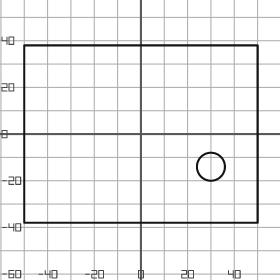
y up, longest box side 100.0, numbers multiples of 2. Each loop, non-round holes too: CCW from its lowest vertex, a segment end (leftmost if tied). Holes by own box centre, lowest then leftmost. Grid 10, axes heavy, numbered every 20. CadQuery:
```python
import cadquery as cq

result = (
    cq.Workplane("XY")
    .moveTo(-50.0, -38.0)
    .lineTo(50.0, -38.0)
    .lineTo(50.0, 38.0)
    .lineTo(-50.0, 38.0)
    .close()
    .moveTo(30.0, -14.0)
    .circle(6.0)
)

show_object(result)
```